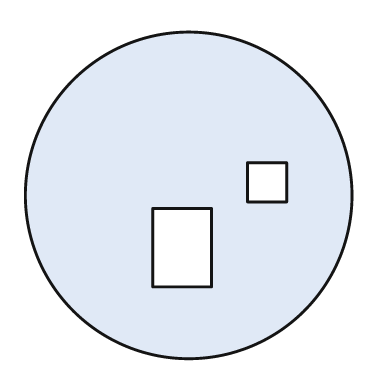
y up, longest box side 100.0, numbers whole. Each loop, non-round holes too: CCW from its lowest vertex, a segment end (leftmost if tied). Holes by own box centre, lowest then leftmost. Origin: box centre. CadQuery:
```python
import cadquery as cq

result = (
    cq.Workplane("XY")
    .moveTo(0.0, 0.0)
    .circle(50.0)
    .moveTo(-11.0, -28.0)
    .lineTo(7.0, -28.0)
    .lineTo(7.0, -4.0)
    .lineTo(-11.0, -4.0)
    .close()
    .moveTo(18.0, -2.0)
    .lineTo(30.0, -2.0)
    .lineTo(30.0, 10.0)
    .lineTo(18.0, 10.0)
    .close()
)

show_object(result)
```